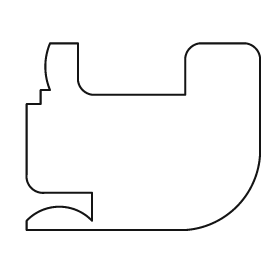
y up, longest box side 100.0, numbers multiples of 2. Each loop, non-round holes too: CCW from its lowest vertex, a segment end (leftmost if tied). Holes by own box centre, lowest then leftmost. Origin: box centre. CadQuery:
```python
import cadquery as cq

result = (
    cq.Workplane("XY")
    .moveTo(-50.0, -40.0)
    .lineTo(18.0, -40.0)
    .threePointArc((40.0, -30.0), (50.0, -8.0))
    .lineTo(50.0, 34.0)
    .threePointArc((48.0, 38.0), (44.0, 40.0))
    .lineTo(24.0, 40.0)
    .threePointArc((20.0, 38.0), (18.0, 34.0))
    .lineTo(18.0, 18.0)
    .lineTo(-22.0, 18.0)
    .threePointArc((-26.0, 20.0), (-28.0, 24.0))
    .lineTo(-28.0, 40.0)
    .lineTo(-40.0, 40.0)
    .threePointArc((-42.0, 30.0), (-40.0, 20.0))
    .lineTo(-44.0, 20.0)
    .lineTo(-44.0, 14.0)
    .lineTo(-50.0, 14.0)
    .lineTo(-50.0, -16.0)
    .threePointArc((-48.0, -22.0), (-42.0, -24.0))
    .lineTo(-22.0, -24.0)
    .lineTo(-22.0, -36.0)
    .threePointArc((-36.0, -30.0), (-50.0, -36.0))
    .close()
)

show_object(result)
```